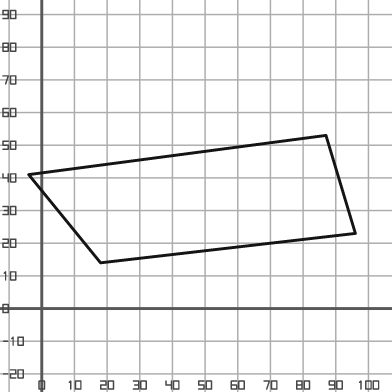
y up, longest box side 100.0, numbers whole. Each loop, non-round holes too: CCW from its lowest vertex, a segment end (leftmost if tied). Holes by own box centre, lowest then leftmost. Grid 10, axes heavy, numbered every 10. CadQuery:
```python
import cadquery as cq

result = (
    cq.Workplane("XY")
    .moveTo(18.0, 14.0)
    .lineTo(96.0, 23.0)
    .lineTo(87.0, 53.0)
    .lineTo(-4.0, 41.0)
    .close()
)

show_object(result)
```